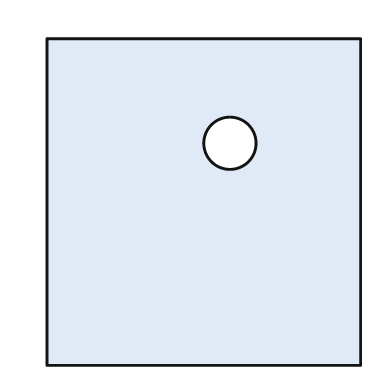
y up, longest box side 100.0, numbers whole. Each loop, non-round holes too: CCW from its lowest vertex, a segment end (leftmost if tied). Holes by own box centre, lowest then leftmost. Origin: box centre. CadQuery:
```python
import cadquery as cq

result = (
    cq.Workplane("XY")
    .moveTo(-48.0, -50.0)
    .lineTo(48.0, -50.0)
    .lineTo(48.0, 50.0)
    .lineTo(-48.0, 50.0)
    .close()
    .moveTo(8.0, 18.0)
    .circle(8.0)
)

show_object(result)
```